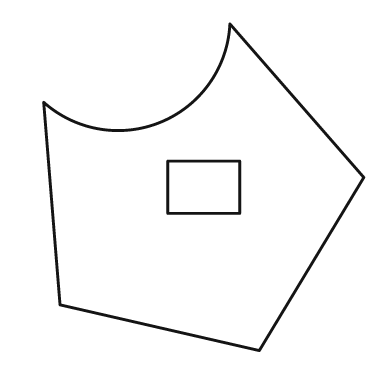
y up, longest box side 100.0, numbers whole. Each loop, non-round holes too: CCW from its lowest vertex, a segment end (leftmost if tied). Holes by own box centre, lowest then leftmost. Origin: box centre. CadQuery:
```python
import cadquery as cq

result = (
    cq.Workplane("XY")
    .moveTo(17.0, -50.0)
    .lineTo(49.0, 3.0)
    .lineTo(8.0, 50.0)
    .threePointArc((-13.0, 20.0), (-49.0, 26.0))
    .lineTo(-44.0, -36.0)
    .close()
    .moveTo(-11.0, -8.0)
    .lineTo(11.0, -8.0)
    .lineTo(11.0, 8.0)
    .lineTo(-11.0, 8.0)
    .close()
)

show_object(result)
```